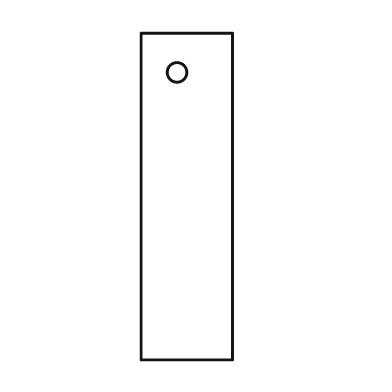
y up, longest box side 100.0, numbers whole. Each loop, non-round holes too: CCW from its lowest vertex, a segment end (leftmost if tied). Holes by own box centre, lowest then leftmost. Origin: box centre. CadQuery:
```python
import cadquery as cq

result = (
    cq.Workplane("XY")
    .moveTo(-14.0, -50.0)
    .lineTo(14.0, -50.0)
    .lineTo(14.0, 50.0)
    .lineTo(-14.0, 50.0)
    .close()
    .moveTo(-3.0, 38.0)
    .circle(3.0)
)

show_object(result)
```